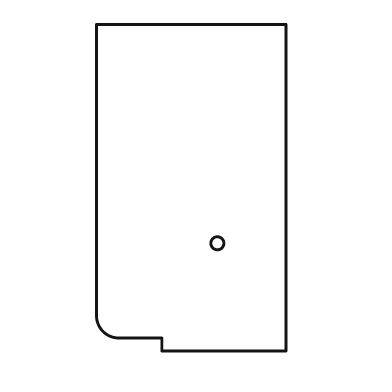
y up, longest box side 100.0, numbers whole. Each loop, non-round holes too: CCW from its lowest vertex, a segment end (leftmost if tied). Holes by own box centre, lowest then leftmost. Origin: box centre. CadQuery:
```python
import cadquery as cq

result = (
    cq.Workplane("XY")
    .moveTo(-9.0, -50.0)
    .lineTo(29.0, -50.0)
    .lineTo(29.0, 50.0)
    .lineTo(-29.0, 50.0)
    .lineTo(-29.0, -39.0)
    .threePointArc((-27.0, -44.0), (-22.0, -46.0))
    .lineTo(-9.0, -46.0)
    .close()
    .moveTo(8.0, -17.0)
    .circle(2.0)
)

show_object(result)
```